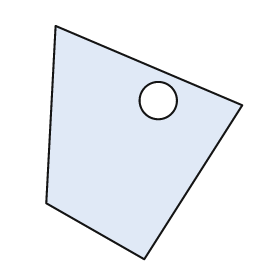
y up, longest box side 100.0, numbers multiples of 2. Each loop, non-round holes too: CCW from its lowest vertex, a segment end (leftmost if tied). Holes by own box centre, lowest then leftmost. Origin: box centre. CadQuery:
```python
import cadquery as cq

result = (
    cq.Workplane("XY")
    .moveTo(0.0, -50.0)
    .lineTo(42.0, 16.0)
    .lineTo(-38.0, 50.0)
    .lineTo(-42.0, -26.0)
    .close()
    .moveTo(6.0, 18.0)
    .circle(8.0)
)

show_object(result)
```